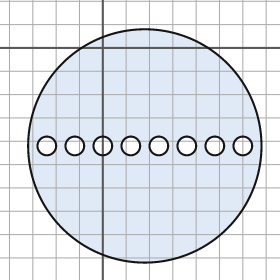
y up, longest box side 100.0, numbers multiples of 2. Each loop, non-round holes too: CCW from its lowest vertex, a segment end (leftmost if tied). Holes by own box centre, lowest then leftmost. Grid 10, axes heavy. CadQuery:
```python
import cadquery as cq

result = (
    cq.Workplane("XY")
    .moveTo(18.0, -42.0)
    .circle(50.0)
    .moveTo(-24.0, -42.0)
    .circle(4.0)
    .moveTo(-12.0, -42.0)
    .circle(4.0)
    .moveTo(0.0, -42.0)
    .circle(4.0)
    .moveTo(12.0, -42.0)
    .circle(4.0)
    .moveTo(24.0, -42.0)
    .circle(4.0)
    .moveTo(36.0, -42.0)
    .circle(4.0)
    .moveTo(48.0, -42.0)
    .circle(4.0)
    .moveTo(60.0, -42.0)
    .circle(4.0)
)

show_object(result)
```